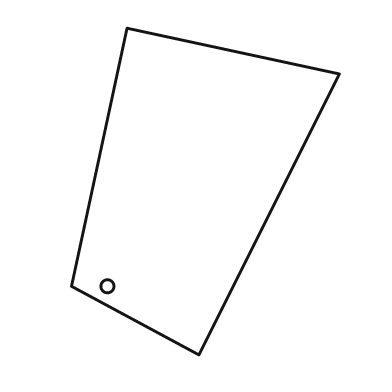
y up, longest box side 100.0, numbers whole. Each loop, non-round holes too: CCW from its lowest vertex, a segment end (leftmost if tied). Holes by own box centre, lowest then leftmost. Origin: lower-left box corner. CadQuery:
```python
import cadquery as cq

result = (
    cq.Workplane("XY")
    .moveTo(39.0, 0.0)
    .lineTo(82.0, 86.0)
    .lineTo(17.0, 100.0)
    .lineTo(0.0, 21.0)
    .close()
    .moveTo(11.0, 21.0)
    .circle(2.0)
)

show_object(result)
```